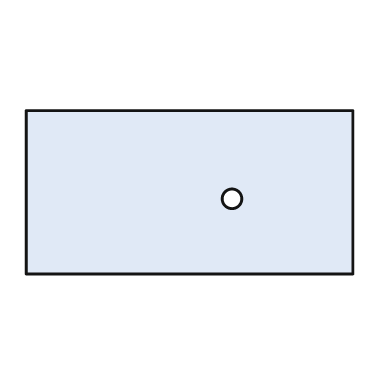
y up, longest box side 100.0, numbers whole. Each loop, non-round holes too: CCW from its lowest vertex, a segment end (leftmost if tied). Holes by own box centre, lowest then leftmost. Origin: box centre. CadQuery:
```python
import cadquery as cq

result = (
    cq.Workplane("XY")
    .moveTo(-50.0, -25.0)
    .lineTo(50.0, -25.0)
    .lineTo(50.0, 25.0)
    .lineTo(-50.0, 25.0)
    .close()
    .moveTo(13.0, -2.0)
    .circle(3.0)
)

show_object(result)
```